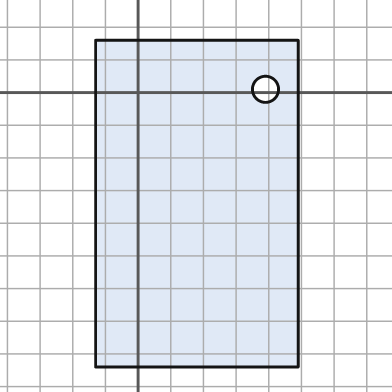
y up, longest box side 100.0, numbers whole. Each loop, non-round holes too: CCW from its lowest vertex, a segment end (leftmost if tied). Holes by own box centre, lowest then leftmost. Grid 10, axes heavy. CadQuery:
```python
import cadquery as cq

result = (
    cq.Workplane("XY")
    .moveTo(-13.0, -84.0)
    .lineTo(49.0, -84.0)
    .lineTo(49.0, 16.0)
    .lineTo(-13.0, 16.0)
    .close()
    .moveTo(39.0, 1.0)
    .circle(4.0)
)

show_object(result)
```